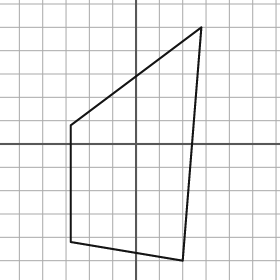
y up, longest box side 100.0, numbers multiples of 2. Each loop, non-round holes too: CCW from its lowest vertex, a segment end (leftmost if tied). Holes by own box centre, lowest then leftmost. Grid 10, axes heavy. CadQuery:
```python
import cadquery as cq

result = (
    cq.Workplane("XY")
    .moveTo(20.0, -50.0)
    .lineTo(28.0, 50.0)
    .lineTo(-28.0, 8.0)
    .lineTo(-28.0, -42.0)
    .close()
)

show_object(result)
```